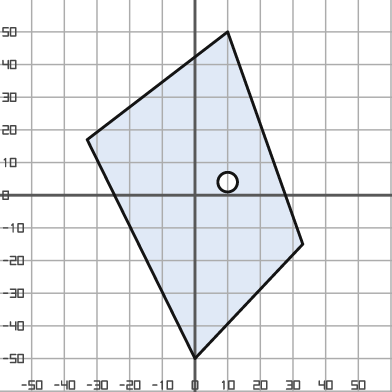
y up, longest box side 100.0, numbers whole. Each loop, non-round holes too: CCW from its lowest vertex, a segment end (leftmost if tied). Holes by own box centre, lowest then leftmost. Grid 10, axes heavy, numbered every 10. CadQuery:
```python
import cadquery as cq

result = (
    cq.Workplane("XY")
    .moveTo(0.0, -50.0)
    .lineTo(33.0, -15.0)
    .lineTo(10.0, 50.0)
    .lineTo(-33.0, 17.0)
    .close()
    .moveTo(10.0, 4.0)
    .circle(3.0)
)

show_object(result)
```